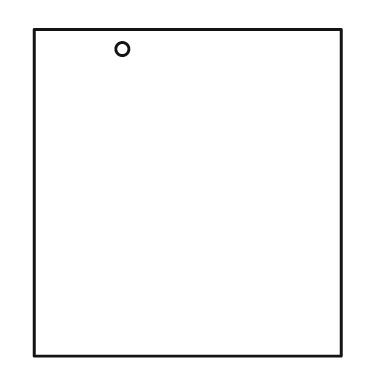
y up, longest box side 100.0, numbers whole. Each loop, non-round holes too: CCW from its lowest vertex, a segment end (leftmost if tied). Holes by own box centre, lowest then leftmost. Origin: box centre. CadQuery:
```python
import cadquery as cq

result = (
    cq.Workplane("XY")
    .moveTo(-47.0, -50.0)
    .lineTo(47.0, -50.0)
    .lineTo(47.0, 50.0)
    .lineTo(-47.0, 50.0)
    .close()
    .moveTo(-20.0, 44.0)
    .circle(2.0)
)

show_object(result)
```